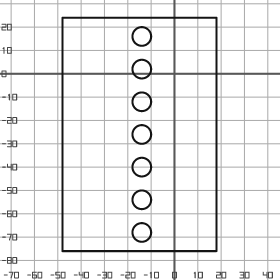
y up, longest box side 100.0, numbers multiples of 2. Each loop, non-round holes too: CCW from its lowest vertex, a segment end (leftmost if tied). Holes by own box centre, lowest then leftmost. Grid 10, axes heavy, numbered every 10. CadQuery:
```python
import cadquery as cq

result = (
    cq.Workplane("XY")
    .moveTo(-48.0, -76.0)
    .lineTo(18.0, -76.0)
    .lineTo(18.0, 24.0)
    .lineTo(-48.0, 24.0)
    .close()
    .moveTo(-14.0, -68.0)
    .circle(4.0)
    .moveTo(-14.0, -54.0)
    .circle(4.0)
    .moveTo(-14.0, -40.0)
    .circle(4.0)
    .moveTo(-14.0, -26.0)
    .circle(4.0)
    .moveTo(-14.0, -12.0)
    .circle(4.0)
    .moveTo(-14.0, 2.0)
    .circle(4.0)
    .moveTo(-14.0, 16.0)
    .circle(4.0)
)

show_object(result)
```